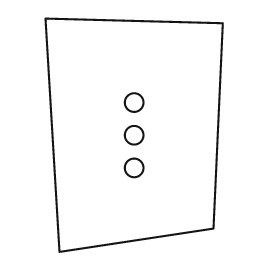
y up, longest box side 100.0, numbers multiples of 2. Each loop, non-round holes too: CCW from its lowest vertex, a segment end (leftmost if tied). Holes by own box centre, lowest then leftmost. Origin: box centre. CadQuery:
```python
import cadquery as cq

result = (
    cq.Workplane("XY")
    .moveTo(-32.0, -50.0)
    .lineTo(34.0, -40.0)
    .lineTo(38.0, 48.0)
    .lineTo(-38.0, 50.0)
    .close()
    .moveTo(0.0, -14.0)
    .circle(4.0)
    .moveTo(0.0, 0.0)
    .circle(4.0)
    .moveTo(0.0, 14.0)
    .circle(4.0)
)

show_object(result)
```